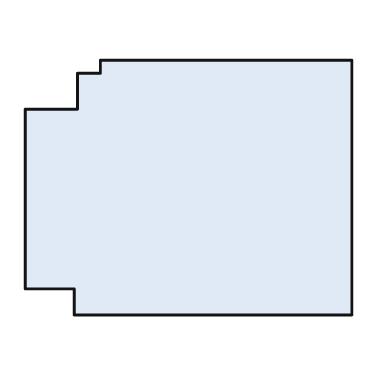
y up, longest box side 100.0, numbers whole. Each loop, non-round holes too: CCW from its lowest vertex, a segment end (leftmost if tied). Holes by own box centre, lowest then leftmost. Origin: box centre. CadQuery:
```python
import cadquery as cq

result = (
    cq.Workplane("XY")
    .moveTo(-35.0, -39.0)
    .lineTo(50.0, -39.0)
    .lineTo(50.0, 39.0)
    .lineTo(-27.0, 39.0)
    .lineTo(-27.0, 35.0)
    .lineTo(-34.0, 35.0)
    .lineTo(-34.0, 24.0)
    .lineTo(-50.0, 24.0)
    .lineTo(-50.0, -31.0)
    .lineTo(-35.0, -31.0)
    .close()
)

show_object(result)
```